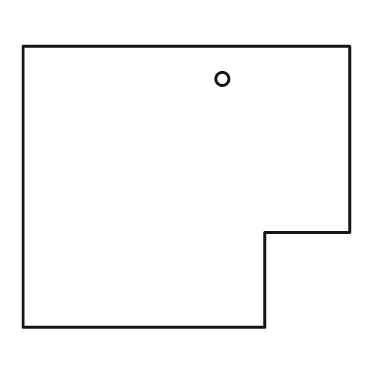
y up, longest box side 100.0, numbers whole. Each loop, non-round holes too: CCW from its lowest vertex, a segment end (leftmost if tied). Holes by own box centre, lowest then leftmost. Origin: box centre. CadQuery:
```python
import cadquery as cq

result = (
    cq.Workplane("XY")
    .moveTo(-50.0, -43.0)
    .lineTo(24.0, -43.0)
    .lineTo(24.0, -14.0)
    .lineTo(50.0, -14.0)
    .lineTo(50.0, 43.0)
    .lineTo(-50.0, 43.0)
    .close()
    .moveTo(11.0, 33.0)
    .circle(2.0)
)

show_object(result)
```